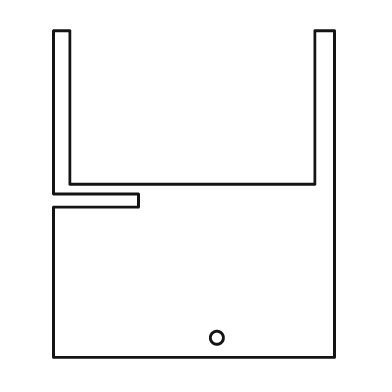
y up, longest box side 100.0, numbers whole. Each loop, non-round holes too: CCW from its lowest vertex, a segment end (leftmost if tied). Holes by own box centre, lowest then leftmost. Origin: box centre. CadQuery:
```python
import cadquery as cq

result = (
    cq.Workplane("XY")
    .moveTo(-43.0, -50.0)
    .lineTo(43.0, -50.0)
    .lineTo(43.0, 50.0)
    .lineTo(37.0, 50.0)
    .lineTo(37.0, 3.0)
    .lineTo(-38.0, 3.0)
    .lineTo(-38.0, 50.0)
    .lineTo(-43.0, 50.0)
    .lineTo(-43.0, 0.0)
    .lineTo(-17.0, 0.0)
    .lineTo(-17.0, -4.0)
    .lineTo(-43.0, -4.0)
    .close()
    .moveTo(7.0, -44.0)
    .circle(2.0)
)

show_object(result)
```